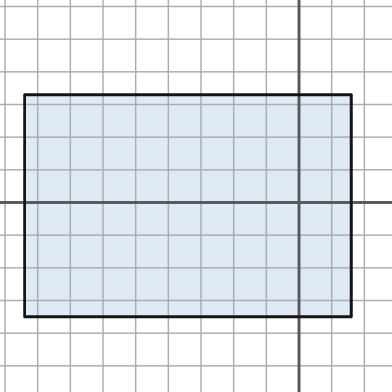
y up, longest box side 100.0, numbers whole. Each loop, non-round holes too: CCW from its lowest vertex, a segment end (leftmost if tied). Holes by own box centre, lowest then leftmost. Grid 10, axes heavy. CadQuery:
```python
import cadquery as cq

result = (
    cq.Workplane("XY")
    .moveTo(-84.0, -35.0)
    .lineTo(16.0, -35.0)
    .lineTo(16.0, 33.0)
    .lineTo(-84.0, 33.0)
    .close()
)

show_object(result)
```